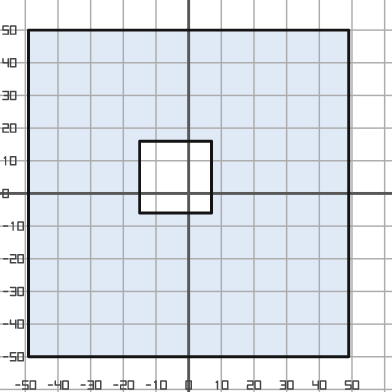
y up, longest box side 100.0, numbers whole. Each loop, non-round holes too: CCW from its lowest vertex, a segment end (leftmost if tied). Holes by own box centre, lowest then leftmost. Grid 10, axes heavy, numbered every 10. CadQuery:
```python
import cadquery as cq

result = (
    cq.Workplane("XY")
    .moveTo(-49.0, -50.0)
    .lineTo(49.0, -50.0)
    .lineTo(49.0, 50.0)
    .lineTo(-49.0, 50.0)
    .close()
    .moveTo(-15.0, -6.0)
    .lineTo(7.0, -6.0)
    .lineTo(7.0, 16.0)
    .lineTo(-15.0, 16.0)
    .close()
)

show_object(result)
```